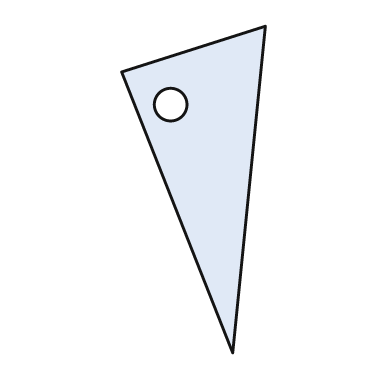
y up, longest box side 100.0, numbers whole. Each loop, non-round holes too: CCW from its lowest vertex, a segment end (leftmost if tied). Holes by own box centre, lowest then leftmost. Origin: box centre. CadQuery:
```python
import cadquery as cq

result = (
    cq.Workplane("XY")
    .moveTo(12.0, -50.0)
    .lineTo(22.0, 50.0)
    .lineTo(-22.0, 36.0)
    .close()
    .moveTo(-7.0, 26.0)
    .circle(5.0)
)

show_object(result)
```